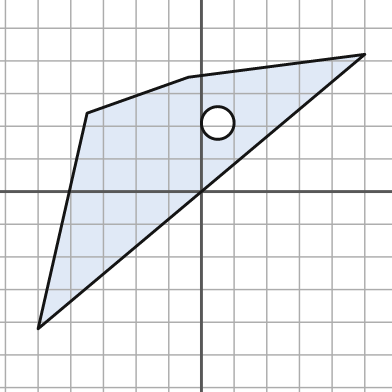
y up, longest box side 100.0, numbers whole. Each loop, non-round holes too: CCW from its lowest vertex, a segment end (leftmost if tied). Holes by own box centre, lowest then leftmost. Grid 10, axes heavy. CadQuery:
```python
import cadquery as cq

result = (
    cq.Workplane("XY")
    .moveTo(-50.0, -42.0)
    .lineTo(50.0, 42.0)
    .lineTo(-4.0, 35.0)
    .lineTo(-35.0, 24.0)
    .close()
    .moveTo(5.0, 21.0)
    .circle(5.0)
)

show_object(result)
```